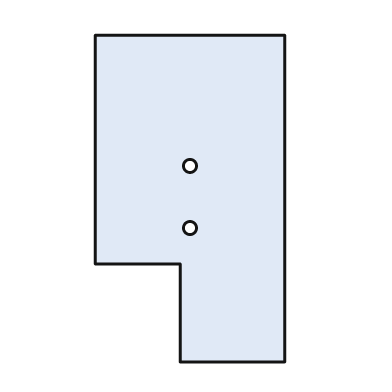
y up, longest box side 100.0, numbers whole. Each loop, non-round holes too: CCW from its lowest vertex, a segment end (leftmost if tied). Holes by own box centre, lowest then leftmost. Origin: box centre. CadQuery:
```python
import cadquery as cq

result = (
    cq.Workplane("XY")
    .moveTo(-3.0, -50.0)
    .lineTo(29.0, -50.0)
    .lineTo(29.0, 50.0)
    .lineTo(-29.0, 50.0)
    .lineTo(-29.0, -20.0)
    .lineTo(-3.0, -20.0)
    .close()
    .moveTo(0.0, -9.0)
    .circle(2.0)
    .moveTo(0.0, 10.0)
    .circle(2.0)
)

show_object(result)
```